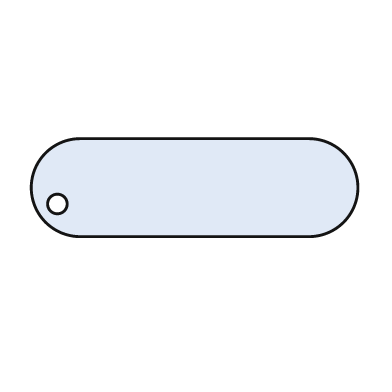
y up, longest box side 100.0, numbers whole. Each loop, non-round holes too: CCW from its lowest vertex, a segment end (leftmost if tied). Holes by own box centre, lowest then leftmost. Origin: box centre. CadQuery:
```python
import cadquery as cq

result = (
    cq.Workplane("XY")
    .moveTo(-35.0, -15.0)
    .lineTo(35.0, -15.0)
    .threePointArc((50.0, 0.0), (35.0, 15.0))
    .lineTo(-35.0, 15.0)
    .threePointArc((-50.0, 0.0), (-35.0, -15.0))
    .close()
    .moveTo(-42.0, -5.0)
    .circle(3.0)
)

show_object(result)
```